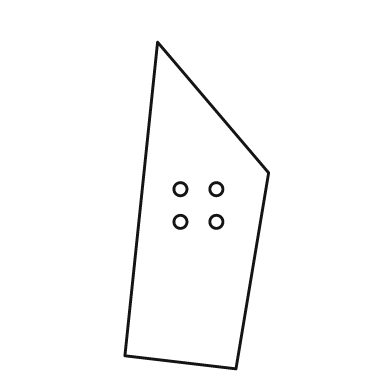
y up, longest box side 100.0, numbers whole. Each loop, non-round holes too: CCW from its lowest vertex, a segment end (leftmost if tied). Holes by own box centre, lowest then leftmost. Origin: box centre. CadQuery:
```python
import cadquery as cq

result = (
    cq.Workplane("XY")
    .moveTo(12.0, -50.0)
    .lineTo(22.0, 10.0)
    .lineTo(-12.0, 50.0)
    .lineTo(-22.0, -46.0)
    .close()
    .moveTo(-5.0, -5.0)
    .circle(2.0)
    .moveTo(6.0, -5.0)
    .circle(2.0)
    .moveTo(-5.0, 5.0)
    .circle(2.0)
    .moveTo(6.0, 5.0)
    .circle(2.0)
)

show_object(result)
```